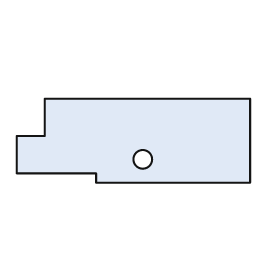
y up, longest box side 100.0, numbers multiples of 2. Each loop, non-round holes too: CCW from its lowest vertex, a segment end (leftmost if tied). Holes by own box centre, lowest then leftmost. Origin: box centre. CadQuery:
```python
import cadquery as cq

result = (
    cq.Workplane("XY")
    .moveTo(-16.0, -18.0)
    .lineTo(50.0, -18.0)
    .lineTo(50.0, 18.0)
    .lineTo(-38.0, 18.0)
    .lineTo(-38.0, 2.0)
    .lineTo(-50.0, 2.0)
    .lineTo(-50.0, -14.0)
    .lineTo(-16.0, -14.0)
    .close()
    .moveTo(4.0, -8.0)
    .circle(4.0)
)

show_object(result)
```